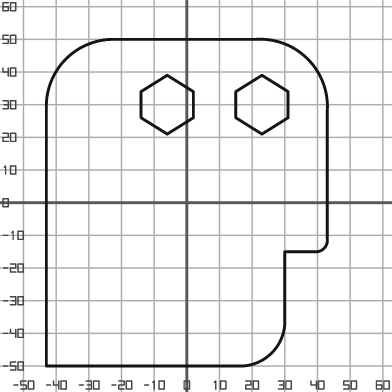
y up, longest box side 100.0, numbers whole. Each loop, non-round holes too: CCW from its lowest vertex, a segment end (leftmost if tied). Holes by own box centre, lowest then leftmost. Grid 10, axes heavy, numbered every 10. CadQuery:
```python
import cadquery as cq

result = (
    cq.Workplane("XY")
    .moveTo(-43.0, -50.0)
    .lineTo(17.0, -50.0)
    .threePointArc((26.0, -46.0), (30.0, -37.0))
    .lineTo(30.0, -15.0)
    .lineTo(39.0, -15.0)
    .threePointArc((42.0, -14.0), (43.0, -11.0))
    .lineTo(43.0, 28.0)
    .threePointArc((37.0, 44.0), (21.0, 50.0))
    .lineTo(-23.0, 50.0)
    .threePointArc((-37.0, 44.0), (-43.0, 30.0))
    .close()
    .moveTo(-6.0, 21.0)
    .lineTo(2.0, 26.0)
    .lineTo(2.0, 34.0)
    .lineTo(-6.0, 39.0)
    .lineTo(-14.0, 34.0)
    .lineTo(-14.0, 26.0)
    .close()
    .moveTo(23.0, 21.0)
    .lineTo(31.0, 26.0)
    .lineTo(31.0, 34.0)
    .lineTo(23.0, 39.0)
    .lineTo(15.0, 34.0)
    .lineTo(15.0, 26.0)
    .close()
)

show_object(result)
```